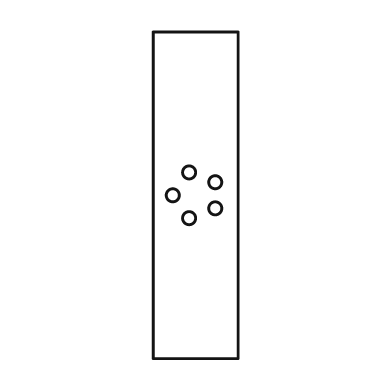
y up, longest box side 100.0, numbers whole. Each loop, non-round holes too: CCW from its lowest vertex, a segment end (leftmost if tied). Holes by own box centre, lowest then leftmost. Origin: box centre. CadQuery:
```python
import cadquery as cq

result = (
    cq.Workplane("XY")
    .moveTo(-13.0, -50.0)
    .lineTo(13.0, -50.0)
    .lineTo(13.0, 50.0)
    .lineTo(-13.0, 50.0)
    .close()
    .moveTo(-2.0, -7.0)
    .circle(2.0)
    .moveTo(6.0, -4.0)
    .circle(2.0)
    .moveTo(-7.0, 0.0)
    .circle(2.0)
    .moveTo(6.0, 4.0)
    .circle(2.0)
    .moveTo(-2.0, 7.0)
    .circle(2.0)
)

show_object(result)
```